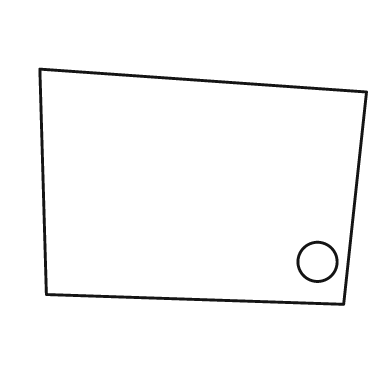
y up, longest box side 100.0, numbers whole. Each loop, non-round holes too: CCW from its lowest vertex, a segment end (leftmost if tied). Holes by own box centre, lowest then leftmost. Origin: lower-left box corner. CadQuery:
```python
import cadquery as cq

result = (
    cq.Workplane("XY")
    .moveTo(93.0, 0.0)
    .lineTo(100.0, 65.0)
    .lineTo(0.0, 72.0)
    .lineTo(2.0, 3.0)
    .close()
    .moveTo(85.0, 13.0)
    .circle(6.0)
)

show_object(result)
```